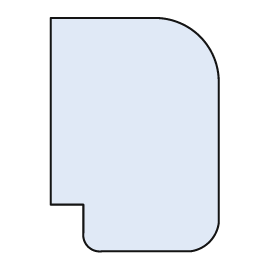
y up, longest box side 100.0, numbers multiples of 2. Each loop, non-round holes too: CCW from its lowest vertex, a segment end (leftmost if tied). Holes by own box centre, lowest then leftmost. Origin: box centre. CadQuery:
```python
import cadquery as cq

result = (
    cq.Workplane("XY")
    .moveTo(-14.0, -50.0)
    .lineTo(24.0, -50.0)
    .threePointArc((32.0, -46.0), (36.0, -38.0))
    .lineTo(36.0, 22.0)
    .threePointArc((28.0, 42.0), (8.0, 50.0))
    .lineTo(-36.0, 50.0)
    .lineTo(-36.0, -30.0)
    .lineTo(-22.0, -30.0)
    .lineTo(-22.0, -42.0)
    .threePointArc((-20.0, -48.0), (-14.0, -50.0))
    .close()
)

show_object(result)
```